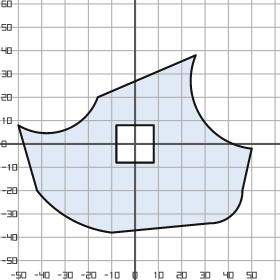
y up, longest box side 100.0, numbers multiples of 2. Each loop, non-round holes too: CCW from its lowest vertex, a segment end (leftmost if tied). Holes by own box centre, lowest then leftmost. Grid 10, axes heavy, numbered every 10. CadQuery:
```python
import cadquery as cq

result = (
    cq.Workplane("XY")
    .moveTo(-10.0, -38.0)
    .lineTo(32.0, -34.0)
    .threePointArc((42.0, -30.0), (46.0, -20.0))
    .lineTo(50.0, -2.0)
    .threePointArc((28.0, 12.0), (26.0, 38.0))
    .lineTo(-16.0, 20.0)
    .threePointArc((-30.0, 6.0), (-50.0, 8.0))
    .lineTo(-42.0, -20.0)
    .threePointArc((-28.0, -32.0), (-10.0, -38.0))
    .close()
    .moveTo(-8.0, -8.0)
    .lineTo(8.0, -8.0)
    .lineTo(8.0, 8.0)
    .lineTo(-8.0, 8.0)
    .close()
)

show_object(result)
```